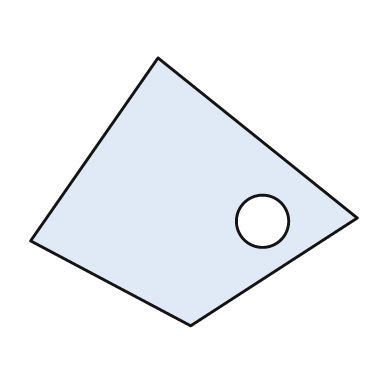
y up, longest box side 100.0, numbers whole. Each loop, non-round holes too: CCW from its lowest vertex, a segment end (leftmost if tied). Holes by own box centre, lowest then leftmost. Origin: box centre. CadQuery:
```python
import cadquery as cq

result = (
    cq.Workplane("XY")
    .moveTo(-1.0, -41.0)
    .lineTo(50.0, -8.0)
    .lineTo(-11.0, 41.0)
    .lineTo(-50.0, -15.0)
    .close()
    .moveTo(21.0, -9.0)
    .circle(8.0)
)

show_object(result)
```